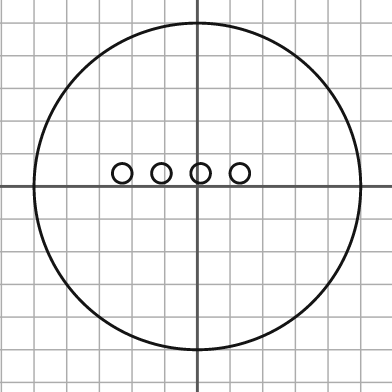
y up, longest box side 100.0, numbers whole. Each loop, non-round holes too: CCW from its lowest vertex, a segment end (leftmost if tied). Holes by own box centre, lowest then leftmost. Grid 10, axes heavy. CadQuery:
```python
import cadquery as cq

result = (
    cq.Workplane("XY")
    .moveTo(0.0, 0.0)
    .circle(50.0)
    .moveTo(-23.0, 4.0)
    .circle(3.0)
    .moveTo(-11.0, 4.0)
    .circle(3.0)
    .moveTo(1.0, 4.0)
    .circle(3.0)
    .moveTo(13.0, 4.0)
    .circle(3.0)
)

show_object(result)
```